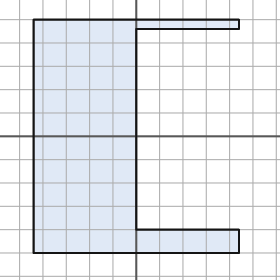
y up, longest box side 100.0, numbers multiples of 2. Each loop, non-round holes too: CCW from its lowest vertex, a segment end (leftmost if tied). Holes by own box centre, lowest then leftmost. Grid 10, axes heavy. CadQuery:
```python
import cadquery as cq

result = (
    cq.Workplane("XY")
    .moveTo(-44.0, -50.0)
    .lineTo(44.0, -50.0)
    .lineTo(44.0, -40.0)
    .lineTo(0.0, -40.0)
    .lineTo(0.0, 46.0)
    .lineTo(44.0, 46.0)
    .lineTo(44.0, 50.0)
    .lineTo(-44.0, 50.0)
    .close()
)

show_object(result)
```